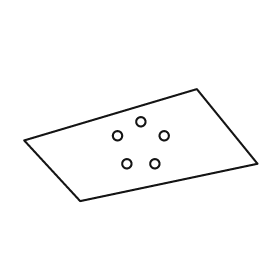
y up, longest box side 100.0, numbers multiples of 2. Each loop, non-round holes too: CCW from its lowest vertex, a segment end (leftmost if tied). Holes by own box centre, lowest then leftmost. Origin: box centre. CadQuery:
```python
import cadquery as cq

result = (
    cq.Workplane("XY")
    .moveTo(-26.0, -24.0)
    .lineTo(50.0, -8.0)
    .lineTo(24.0, 24.0)
    .lineTo(-50.0, 2.0)
    .close()
    .moveTo(-6.0, -8.0)
    .circle(2.0)
    .moveTo(6.0, -8.0)
    .circle(2.0)
    .moveTo(-10.0, 4.0)
    .circle(2.0)
    .moveTo(10.0, 4.0)
    .circle(2.0)
    .moveTo(0.0, 10.0)
    .circle(2.0)
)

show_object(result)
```